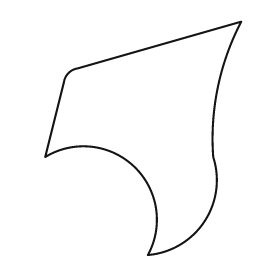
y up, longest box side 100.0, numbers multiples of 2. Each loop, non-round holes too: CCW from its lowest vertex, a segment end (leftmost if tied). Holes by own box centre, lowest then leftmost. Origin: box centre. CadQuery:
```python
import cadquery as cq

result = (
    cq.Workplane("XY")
    .moveTo(2.0, -50.0)
    .threePointArc((26.0, -36.0), (30.0, -8.0))
    .threePointArc((32.0, 22.0), (42.0, 50.0))
    .lineTo(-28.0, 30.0)
    .threePointArc((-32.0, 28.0), (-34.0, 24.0))
    .lineTo(-42.0, -8.0)
    .threePointArc((-4.0, -12.0), (2.0, -50.0))
    .close()
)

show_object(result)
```